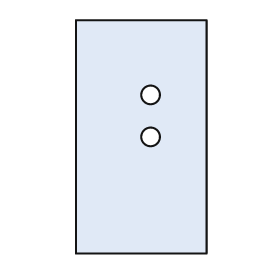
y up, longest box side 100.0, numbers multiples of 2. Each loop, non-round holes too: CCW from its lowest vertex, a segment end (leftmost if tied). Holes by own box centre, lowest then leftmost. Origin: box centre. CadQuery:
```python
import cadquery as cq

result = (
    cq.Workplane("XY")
    .moveTo(-28.0, -50.0)
    .lineTo(28.0, -50.0)
    .lineTo(28.0, 50.0)
    .lineTo(-28.0, 50.0)
    .close()
    .moveTo(4.0, 0.0)
    .circle(4.0)
    .moveTo(4.0, 18.0)
    .circle(4.0)
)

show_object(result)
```